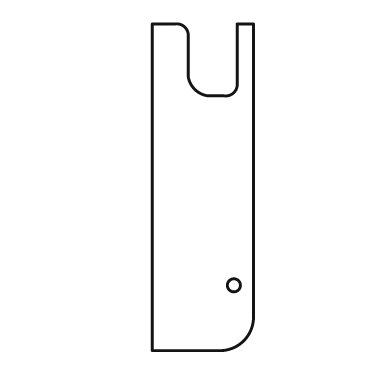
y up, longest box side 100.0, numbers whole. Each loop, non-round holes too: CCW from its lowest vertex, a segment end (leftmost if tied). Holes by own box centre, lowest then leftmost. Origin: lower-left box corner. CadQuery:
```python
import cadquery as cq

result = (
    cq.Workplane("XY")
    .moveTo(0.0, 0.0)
    .lineTo(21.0, 0.0)
    .threePointArc((28.0, 3.0), (31.0, 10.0))
    .lineTo(31.0, 100.0)
    .lineTo(26.0, 100.0)
    .lineTo(26.0, 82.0)
    .threePointArc((25.0, 79.0), (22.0, 78.0))
    .lineTo(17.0, 78.0)
    .threePointArc((13.0, 80.0), (11.0, 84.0))
    .lineTo(11.0, 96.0)
    .threePointArc((10.0, 99.0), (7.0, 100.0))
    .lineTo(0.0, 100.0)
    .close()
    .moveTo(25.0, 20.0)
    .circle(2.0)
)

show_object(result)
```